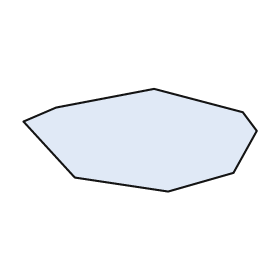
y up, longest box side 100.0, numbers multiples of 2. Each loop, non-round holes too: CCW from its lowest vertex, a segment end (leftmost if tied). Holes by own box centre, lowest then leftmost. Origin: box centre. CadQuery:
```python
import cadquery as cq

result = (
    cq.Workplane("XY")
    .moveTo(12.0, -22.0)
    .lineTo(40.0, -14.0)
    .lineTo(50.0, 4.0)
    .lineTo(44.0, 12.0)
    .lineTo(6.0, 22.0)
    .lineTo(-36.0, 14.0)
    .lineTo(-50.0, 8.0)
    .lineTo(-28.0, -16.0)
    .close()
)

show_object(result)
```